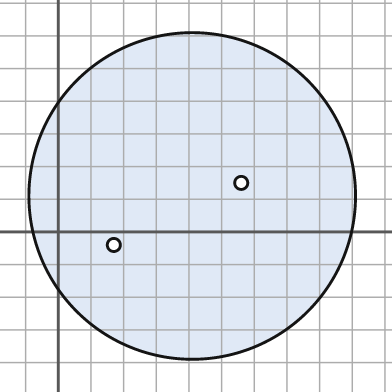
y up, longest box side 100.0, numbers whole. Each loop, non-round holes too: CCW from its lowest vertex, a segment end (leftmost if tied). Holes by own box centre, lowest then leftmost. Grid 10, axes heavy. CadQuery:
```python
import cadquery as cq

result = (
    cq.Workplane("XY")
    .moveTo(41.0, 11.0)
    .circle(50.0)
    .moveTo(17.0, -4.0)
    .circle(2.0)
    .moveTo(56.0, 15.0)
    .circle(2.0)
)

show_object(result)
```